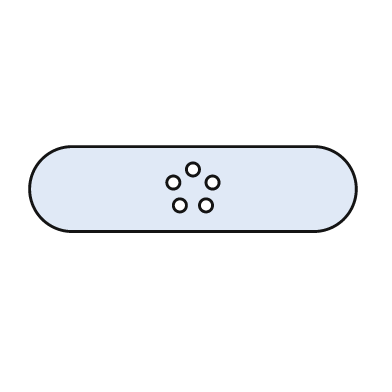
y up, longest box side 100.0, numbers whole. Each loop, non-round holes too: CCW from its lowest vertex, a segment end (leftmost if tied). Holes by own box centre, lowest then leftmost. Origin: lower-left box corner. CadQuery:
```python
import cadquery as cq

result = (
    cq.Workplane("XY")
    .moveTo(13.0, 0.0)
    .lineTo(87.0, 0.0)
    .threePointArc((100.0, 13.0), (87.0, 26.0))
    .lineTo(13.0, 26.0)
    .threePointArc((0.0, 13.0), (13.0, 0.0))
    .close()
    .moveTo(46.0, 8.0)
    .circle(2.0)
    .moveTo(54.0, 8.0)
    .circle(2.0)
    .moveTo(44.0, 15.0)
    .circle(2.0)
    .moveTo(56.0, 15.0)
    .circle(2.0)
    .moveTo(50.0, 19.0)
    .circle(2.0)
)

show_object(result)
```